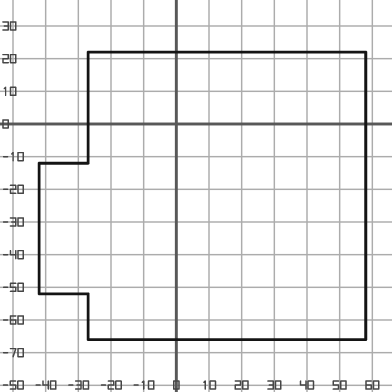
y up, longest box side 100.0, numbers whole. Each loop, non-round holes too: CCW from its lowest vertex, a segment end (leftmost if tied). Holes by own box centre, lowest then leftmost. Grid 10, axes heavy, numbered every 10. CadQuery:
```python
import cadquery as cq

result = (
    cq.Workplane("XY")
    .moveTo(-27.0, -66.0)
    .lineTo(58.0, -66.0)
    .lineTo(58.0, 22.0)
    .lineTo(-27.0, 22.0)
    .lineTo(-27.0, -12.0)
    .lineTo(-42.0, -12.0)
    .lineTo(-42.0, -52.0)
    .lineTo(-27.0, -52.0)
    .close()
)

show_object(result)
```